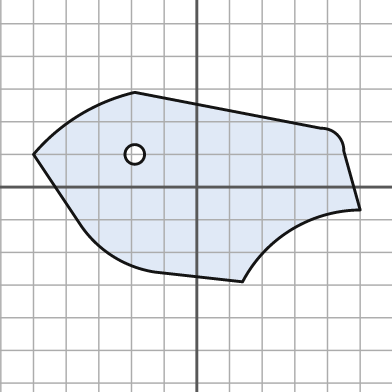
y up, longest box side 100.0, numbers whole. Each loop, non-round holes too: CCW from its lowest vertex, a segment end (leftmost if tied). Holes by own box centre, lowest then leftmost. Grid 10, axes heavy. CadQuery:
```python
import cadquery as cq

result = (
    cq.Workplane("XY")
    .moveTo(14.0, -29.0)
    .threePointArc((29.0, -13.0), (50.0, -7.0))
    .lineTo(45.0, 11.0)
    .threePointArc((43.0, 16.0), (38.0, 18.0))
    .lineTo(-19.0, 29.0)
    .threePointArc((-36.0, 22.0), (-50.0, 10.0))
    .lineTo(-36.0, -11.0)
    .threePointArc((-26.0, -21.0), (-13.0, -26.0))
    .close()
    .moveTo(-19.0, 10.0)
    .circle(3.0)
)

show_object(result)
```